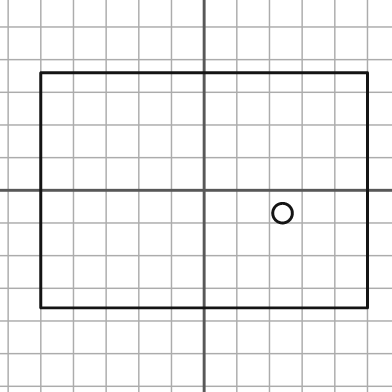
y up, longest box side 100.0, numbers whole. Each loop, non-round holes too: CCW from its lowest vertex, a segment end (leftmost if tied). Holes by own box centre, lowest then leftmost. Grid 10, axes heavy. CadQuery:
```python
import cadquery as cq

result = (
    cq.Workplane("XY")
    .moveTo(-50.0, -36.0)
    .lineTo(50.0, -36.0)
    .lineTo(50.0, 36.0)
    .lineTo(-50.0, 36.0)
    .close()
    .moveTo(24.0, -7.0)
    .circle(3.0)
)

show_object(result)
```